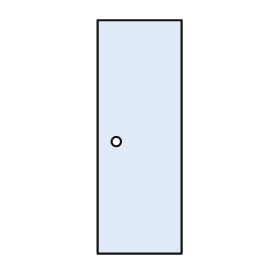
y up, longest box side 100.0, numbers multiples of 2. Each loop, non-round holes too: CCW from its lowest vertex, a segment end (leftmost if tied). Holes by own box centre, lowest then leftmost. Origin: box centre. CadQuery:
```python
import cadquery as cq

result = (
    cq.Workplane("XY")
    .moveTo(-18.0, -50.0)
    .lineTo(18.0, -50.0)
    .lineTo(18.0, 50.0)
    .lineTo(-18.0, 50.0)
    .close()
    .moveTo(-10.0, -2.0)
    .circle(2.0)
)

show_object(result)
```